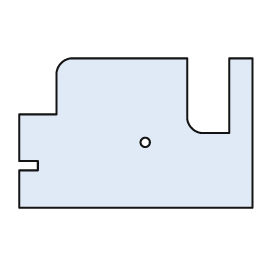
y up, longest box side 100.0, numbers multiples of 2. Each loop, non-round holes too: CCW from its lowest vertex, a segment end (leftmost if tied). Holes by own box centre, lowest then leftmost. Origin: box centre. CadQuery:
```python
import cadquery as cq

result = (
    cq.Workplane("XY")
    .moveTo(-50.0, -32.0)
    .lineTo(50.0, -32.0)
    .lineTo(50.0, 32.0)
    .lineTo(40.0, 32.0)
    .lineTo(40.0, 0.0)
    .lineTo(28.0, 0.0)
    .threePointArc((24.0, 2.0), (22.0, 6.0))
    .lineTo(22.0, 32.0)
    .lineTo(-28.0, 32.0)
    .threePointArc((-32.0, 30.0), (-34.0, 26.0))
    .lineTo(-34.0, 8.0)
    .lineTo(-50.0, 8.0)
    .lineTo(-50.0, -12.0)
    .lineTo(-42.0, -12.0)
    .lineTo(-42.0, -16.0)
    .lineTo(-50.0, -16.0)
    .close()
    .moveTo(4.0, -4.0)
    .circle(2.0)
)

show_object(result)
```